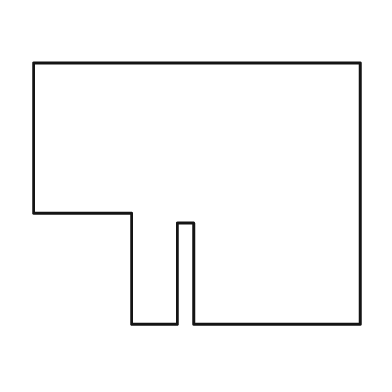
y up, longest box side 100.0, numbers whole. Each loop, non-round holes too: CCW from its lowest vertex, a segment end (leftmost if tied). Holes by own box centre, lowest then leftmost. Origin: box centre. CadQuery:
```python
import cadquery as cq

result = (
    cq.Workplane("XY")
    .moveTo(-20.0, -40.0)
    .lineTo(-6.0, -40.0)
    .lineTo(-6.0, -9.0)
    .lineTo(-1.0, -9.0)
    .lineTo(-1.0, -40.0)
    .lineTo(50.0, -40.0)
    .lineTo(50.0, 40.0)
    .lineTo(-50.0, 40.0)
    .lineTo(-50.0, -6.0)
    .lineTo(-20.0, -6.0)
    .close()
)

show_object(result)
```